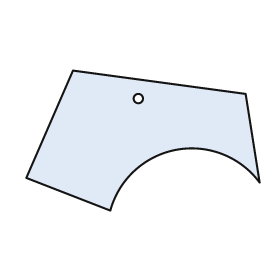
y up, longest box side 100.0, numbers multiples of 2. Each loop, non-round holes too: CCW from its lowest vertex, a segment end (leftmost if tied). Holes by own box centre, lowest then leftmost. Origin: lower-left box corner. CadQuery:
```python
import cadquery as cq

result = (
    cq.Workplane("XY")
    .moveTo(36.0, 0.0)
    .threePointArc((64.0, 26.0), (100.0, 12.0))
    .lineTo(94.0, 50.0)
    .lineTo(20.0, 60.0)
    .lineTo(0.0, 14.0)
    .close()
    .moveTo(48.0, 48.0)
    .circle(2.0)
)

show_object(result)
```